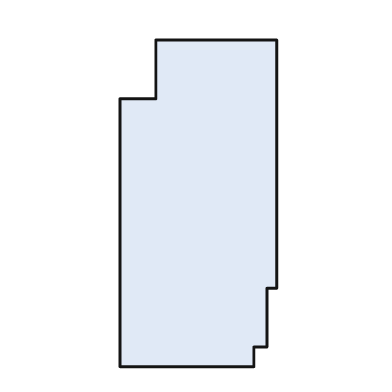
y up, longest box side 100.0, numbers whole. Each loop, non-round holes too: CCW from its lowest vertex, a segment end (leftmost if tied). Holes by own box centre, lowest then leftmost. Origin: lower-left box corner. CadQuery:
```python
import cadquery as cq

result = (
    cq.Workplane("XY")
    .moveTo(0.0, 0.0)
    .lineTo(41.0, 0.0)
    .lineTo(41.0, 6.0)
    .lineTo(45.0, 6.0)
    .lineTo(45.0, 24.0)
    .lineTo(48.0, 24.0)
    .lineTo(48.0, 100.0)
    .lineTo(11.0, 100.0)
    .lineTo(11.0, 82.0)
    .lineTo(0.0, 82.0)
    .close()
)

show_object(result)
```